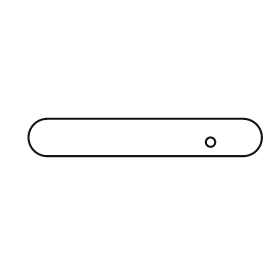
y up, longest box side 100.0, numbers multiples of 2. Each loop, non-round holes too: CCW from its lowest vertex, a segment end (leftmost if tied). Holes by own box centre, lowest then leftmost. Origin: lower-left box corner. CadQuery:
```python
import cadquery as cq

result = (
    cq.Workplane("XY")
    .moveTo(8.0, 0.0)
    .lineTo(92.0, 0.0)
    .threePointArc((100.0, 8.0), (92.0, 16.0))
    .lineTo(8.0, 16.0)
    .threePointArc((0.0, 8.0), (8.0, 0.0))
    .close()
    .moveTo(78.0, 6.0)
    .circle(2.0)
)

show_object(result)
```